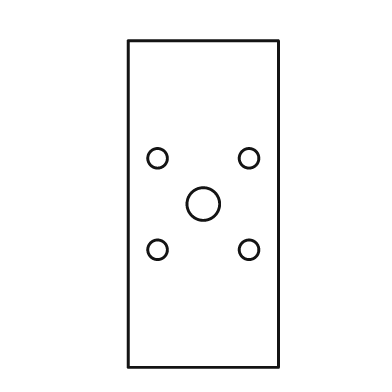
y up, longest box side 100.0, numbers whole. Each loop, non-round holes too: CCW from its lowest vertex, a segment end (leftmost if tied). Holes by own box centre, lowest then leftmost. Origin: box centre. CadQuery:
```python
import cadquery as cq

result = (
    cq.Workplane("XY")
    .moveTo(-23.0, -50.0)
    .lineTo(23.0, -50.0)
    .lineTo(23.0, 50.0)
    .lineTo(-23.0, 50.0)
    .close()
    .moveTo(-14.0, -14.0)
    .circle(3.0)
    .moveTo(14.0, -14.0)
    .circle(3.0)
    .moveTo(0.0, 0.0)
    .circle(5.0)
    .moveTo(-14.0, 14.0)
    .circle(3.0)
    .moveTo(14.0, 14.0)
    .circle(3.0)
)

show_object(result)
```